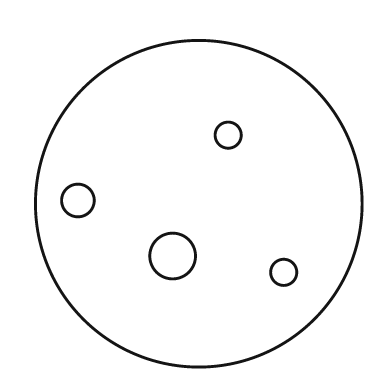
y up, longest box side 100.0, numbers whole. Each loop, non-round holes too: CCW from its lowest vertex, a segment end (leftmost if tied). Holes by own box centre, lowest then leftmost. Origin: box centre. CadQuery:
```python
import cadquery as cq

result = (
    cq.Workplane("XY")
    .moveTo(0.0, 0.0)
    .circle(50.0)
    .moveTo(26.0, -21.0)
    .circle(4.0)
    .moveTo(-8.0, -16.0)
    .circle(7.0)
    .moveTo(-37.0, 1.0)
    .circle(5.0)
    .moveTo(9.0, 21.0)
    .circle(4.0)
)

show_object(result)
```